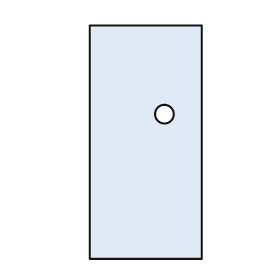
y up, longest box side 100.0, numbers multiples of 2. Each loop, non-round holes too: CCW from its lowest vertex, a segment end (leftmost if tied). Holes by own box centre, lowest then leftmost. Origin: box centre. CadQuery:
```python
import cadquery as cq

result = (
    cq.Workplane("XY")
    .moveTo(-24.0, -50.0)
    .lineTo(24.0, -50.0)
    .lineTo(24.0, 50.0)
    .lineTo(-24.0, 50.0)
    .close()
    .moveTo(8.0, 12.0)
    .circle(4.0)
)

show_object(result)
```